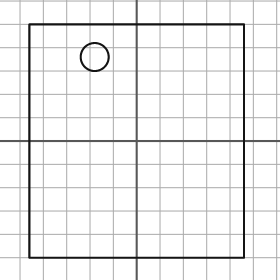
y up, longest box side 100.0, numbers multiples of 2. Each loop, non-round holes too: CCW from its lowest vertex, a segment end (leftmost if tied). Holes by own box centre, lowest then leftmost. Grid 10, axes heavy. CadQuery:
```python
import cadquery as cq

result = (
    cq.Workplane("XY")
    .moveTo(-46.0, -50.0)
    .lineTo(46.0, -50.0)
    .lineTo(46.0, 50.0)
    .lineTo(-46.0, 50.0)
    .close()
    .moveTo(-18.0, 36.0)
    .circle(6.0)
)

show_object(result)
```